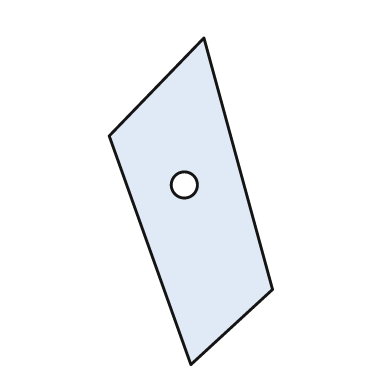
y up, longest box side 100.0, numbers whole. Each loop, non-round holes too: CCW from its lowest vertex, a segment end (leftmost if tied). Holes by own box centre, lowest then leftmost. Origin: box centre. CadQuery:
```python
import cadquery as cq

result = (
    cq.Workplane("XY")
    .moveTo(0.0, -50.0)
    .lineTo(25.0, -27.0)
    .lineTo(4.0, 50.0)
    .lineTo(-25.0, 20.0)
    .close()
    .moveTo(-2.0, 5.0)
    .circle(4.0)
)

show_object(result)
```